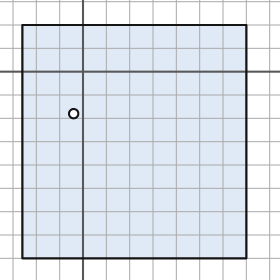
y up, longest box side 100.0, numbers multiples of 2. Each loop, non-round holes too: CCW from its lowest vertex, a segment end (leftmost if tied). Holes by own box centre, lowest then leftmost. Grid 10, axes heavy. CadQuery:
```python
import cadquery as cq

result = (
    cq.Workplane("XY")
    .moveTo(-26.0, -80.0)
    .lineTo(70.0, -80.0)
    .lineTo(70.0, 20.0)
    .lineTo(-26.0, 20.0)
    .close()
    .moveTo(-4.0, -18.0)
    .circle(2.0)
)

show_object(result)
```